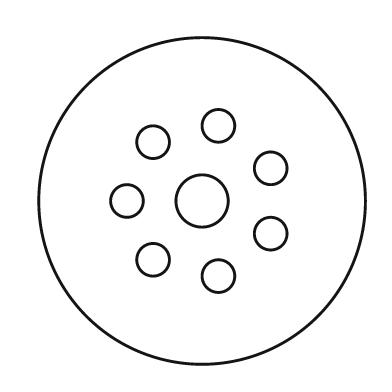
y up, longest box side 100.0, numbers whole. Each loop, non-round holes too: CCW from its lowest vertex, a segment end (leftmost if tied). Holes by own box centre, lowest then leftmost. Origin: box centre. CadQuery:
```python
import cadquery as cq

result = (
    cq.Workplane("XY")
    .moveTo(0.0, 0.0)
    .circle(50.0)
    .moveTo(5.0, -23.0)
    .circle(5.0)
    .moveTo(-15.0, -18.0)
    .circle(5.0)
    .moveTo(21.0, -10.0)
    .circle(5.0)
    .moveTo(-23.0, 0.0)
    .circle(5.0)
    .moveTo(0.0, 0.0)
    .circle(8.0)
    .moveTo(21.0, 10.0)
    .circle(5.0)
    .moveTo(-15.0, 18.0)
    .circle(5.0)
    .moveTo(5.0, 23.0)
    .circle(5.0)
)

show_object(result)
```